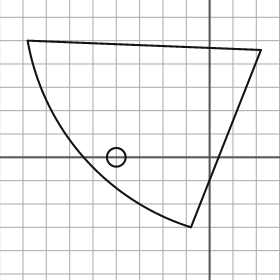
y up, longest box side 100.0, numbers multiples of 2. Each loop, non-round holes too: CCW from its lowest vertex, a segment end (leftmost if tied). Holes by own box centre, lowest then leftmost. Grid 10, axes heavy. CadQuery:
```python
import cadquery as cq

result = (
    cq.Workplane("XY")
    .moveTo(-8.0, -30.0)
    .lineTo(22.0, 46.0)
    .lineTo(-78.0, 50.0)
    .threePointArc((-54.0, 0.0), (-8.0, -30.0))
    .close()
    .moveTo(-40.0, 0.0)
    .circle(4.0)
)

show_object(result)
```